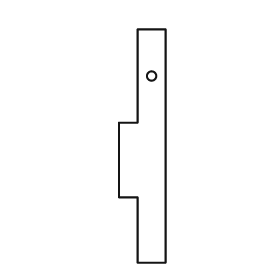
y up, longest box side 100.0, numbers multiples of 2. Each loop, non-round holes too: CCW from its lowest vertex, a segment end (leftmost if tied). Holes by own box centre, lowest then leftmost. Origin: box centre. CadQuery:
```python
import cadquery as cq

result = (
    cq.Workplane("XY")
    .moveTo(-2.0, -50.0)
    .lineTo(10.0, -50.0)
    .lineTo(10.0, 50.0)
    .lineTo(-2.0, 50.0)
    .lineTo(-2.0, 10.0)
    .lineTo(-10.0, 10.0)
    .lineTo(-10.0, -22.0)
    .lineTo(-2.0, -22.0)
    .close()
    .moveTo(4.0, 30.0)
    .circle(2.0)
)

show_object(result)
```